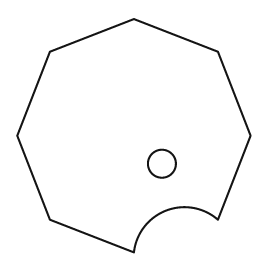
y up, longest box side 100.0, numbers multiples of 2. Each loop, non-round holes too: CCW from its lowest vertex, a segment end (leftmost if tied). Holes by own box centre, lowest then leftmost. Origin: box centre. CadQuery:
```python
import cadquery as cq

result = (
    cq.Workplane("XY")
    .moveTo(0.0, -50.0)
    .threePointArc((14.0, -32.0), (36.0, -36.0))
    .lineTo(50.0, 0.0)
    .lineTo(36.0, 36.0)
    .lineTo(0.0, 50.0)
    .lineTo(-36.0, 36.0)
    .lineTo(-50.0, 0.0)
    .lineTo(-36.0, -36.0)
    .close()
    .moveTo(12.0, -12.0)
    .circle(6.0)
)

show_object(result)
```